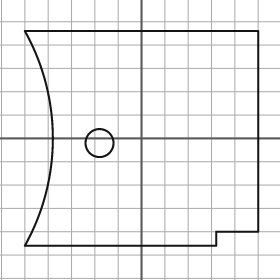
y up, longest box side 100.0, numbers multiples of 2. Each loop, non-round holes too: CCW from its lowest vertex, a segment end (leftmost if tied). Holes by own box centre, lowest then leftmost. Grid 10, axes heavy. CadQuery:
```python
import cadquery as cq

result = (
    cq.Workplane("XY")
    .moveTo(-50.0, -46.0)
    .lineTo(32.0, -46.0)
    .lineTo(32.0, -40.0)
    .lineTo(50.0, -40.0)
    .lineTo(50.0, 46.0)
    .lineTo(-50.0, 46.0)
    .threePointArc((-38.0, 0.0), (-50.0, -46.0))
    .close()
    .moveTo(-18.0, -2.0)
    .circle(6.0)
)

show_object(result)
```